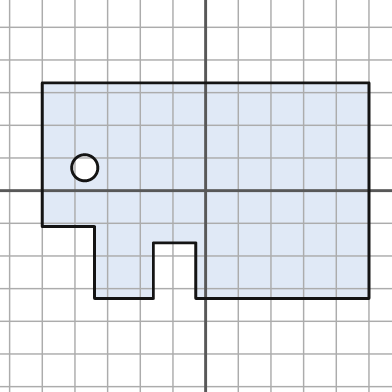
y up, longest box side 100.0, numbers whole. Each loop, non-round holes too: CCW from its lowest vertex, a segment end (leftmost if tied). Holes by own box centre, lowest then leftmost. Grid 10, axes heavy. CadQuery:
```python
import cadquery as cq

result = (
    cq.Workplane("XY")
    .moveTo(-34.0, -33.0)
    .lineTo(-16.0, -33.0)
    .lineTo(-16.0, -16.0)
    .lineTo(-3.0, -16.0)
    .lineTo(-3.0, -33.0)
    .lineTo(50.0, -33.0)
    .lineTo(50.0, 33.0)
    .lineTo(-50.0, 33.0)
    .lineTo(-50.0, -11.0)
    .lineTo(-34.0, -11.0)
    .close()
    .moveTo(-37.0, 7.0)
    .circle(4.0)
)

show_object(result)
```